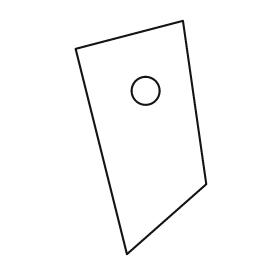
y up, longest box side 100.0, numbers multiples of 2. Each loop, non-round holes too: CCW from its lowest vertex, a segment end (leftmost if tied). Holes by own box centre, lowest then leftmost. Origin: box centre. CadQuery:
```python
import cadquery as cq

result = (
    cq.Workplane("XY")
    .moveTo(-6.0, -50.0)
    .lineTo(28.0, -20.0)
    .lineTo(18.0, 50.0)
    .lineTo(-28.0, 38.0)
    .close()
    .moveTo(2.0, 20.0)
    .circle(6.0)
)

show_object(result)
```